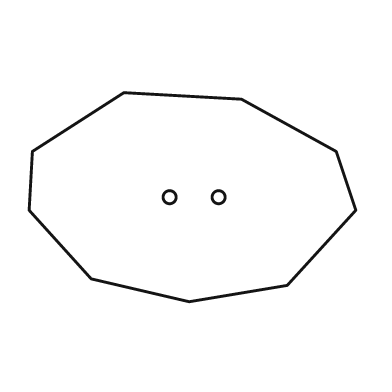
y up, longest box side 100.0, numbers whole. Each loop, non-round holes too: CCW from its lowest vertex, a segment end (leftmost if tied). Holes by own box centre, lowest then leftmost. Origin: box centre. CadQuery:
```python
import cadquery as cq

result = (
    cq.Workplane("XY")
    .moveTo(-1.0, -32.0)
    .lineTo(29.0, -27.0)
    .lineTo(50.0, -4.0)
    .lineTo(44.0, 14.0)
    .lineTo(15.0, 30.0)
    .lineTo(-21.0, 32.0)
    .lineTo(-49.0, 14.0)
    .lineTo(-50.0, -4.0)
    .lineTo(-31.0, -25.0)
    .close()
    .moveTo(-7.0, 0.0)
    .circle(2.0)
    .moveTo(8.0, 0.0)
    .circle(2.0)
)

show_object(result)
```